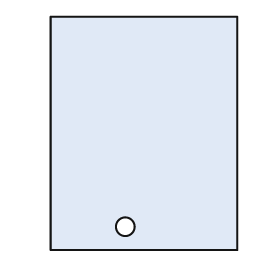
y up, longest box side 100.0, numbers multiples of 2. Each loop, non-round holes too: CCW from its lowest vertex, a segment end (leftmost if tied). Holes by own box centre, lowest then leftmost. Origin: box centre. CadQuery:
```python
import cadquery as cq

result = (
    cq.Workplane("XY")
    .moveTo(-40.0, -50.0)
    .lineTo(40.0, -50.0)
    .lineTo(40.0, 50.0)
    .lineTo(-40.0, 50.0)
    .close()
    .moveTo(-8.0, -40.0)
    .circle(4.0)
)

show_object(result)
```